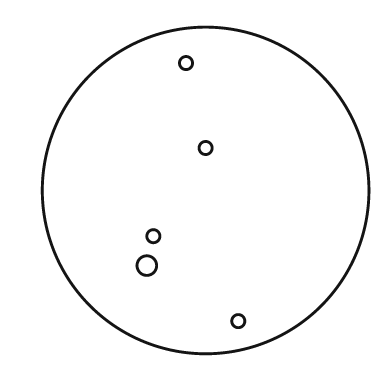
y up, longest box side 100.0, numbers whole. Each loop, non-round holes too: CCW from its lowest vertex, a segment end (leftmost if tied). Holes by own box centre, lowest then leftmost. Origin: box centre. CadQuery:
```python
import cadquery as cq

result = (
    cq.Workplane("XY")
    .moveTo(0.0, 0.0)
    .circle(50.0)
    .moveTo(10.0, -40.0)
    .circle(2.0)
    .moveTo(-18.0, -23.0)
    .circle(3.0)
    .moveTo(-16.0, -14.0)
    .circle(2.0)
    .moveTo(0.0, 13.0)
    .circle(2.0)
    .moveTo(-6.0, 39.0)
    .circle(2.0)
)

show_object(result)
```